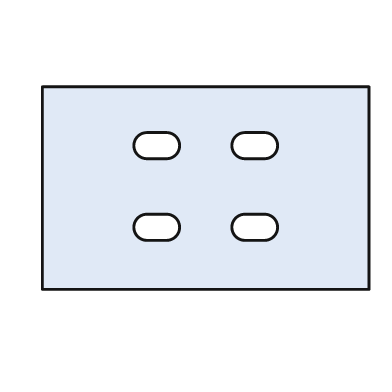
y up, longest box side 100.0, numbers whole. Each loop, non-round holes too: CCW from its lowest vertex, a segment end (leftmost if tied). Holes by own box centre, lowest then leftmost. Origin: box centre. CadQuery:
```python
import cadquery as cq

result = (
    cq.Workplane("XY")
    .moveTo(-50.0, -31.0)
    .lineTo(50.0, -31.0)
    .lineTo(50.0, 31.0)
    .lineTo(-50.0, 31.0)
    .close()
    .moveTo(-18.0, -16.0)
    .lineTo(-12.0, -16.0)
    .threePointArc((-8.0, -12.0), (-12.0, -8.0))
    .lineTo(-18.0, -8.0)
    .threePointArc((-22.0, -12.0), (-18.0, -16.0))
    .close()
    .moveTo(12.0, -16.0)
    .lineTo(18.0, -16.0)
    .threePointArc((22.0, -12.0), (18.0, -8.0))
    .lineTo(12.0, -8.0)
    .threePointArc((8.0, -12.0), (12.0, -16.0))
    .close()
    .moveTo(-18.0, 9.0)
    .lineTo(-12.0, 9.0)
    .threePointArc((-8.0, 13.0), (-12.0, 17.0))
    .lineTo(-18.0, 17.0)
    .threePointArc((-22.0, 13.0), (-18.0, 9.0))
    .close()
    .moveTo(12.0, 9.0)
    .lineTo(18.0, 9.0)
    .threePointArc((22.0, 13.0), (18.0, 17.0))
    .lineTo(12.0, 17.0)
    .threePointArc((8.0, 13.0), (12.0, 9.0))
    .close()
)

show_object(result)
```